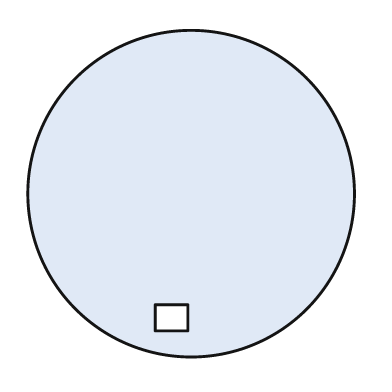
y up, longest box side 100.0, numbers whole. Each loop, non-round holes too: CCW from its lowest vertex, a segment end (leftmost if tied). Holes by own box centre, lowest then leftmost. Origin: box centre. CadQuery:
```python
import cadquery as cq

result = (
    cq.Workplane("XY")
    .moveTo(0.0, 0.0)
    .circle(50.0)
    .moveTo(-11.0, -42.0)
    .lineTo(-1.0, -42.0)
    .lineTo(-1.0, -34.0)
    .lineTo(-11.0, -34.0)
    .close()
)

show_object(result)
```